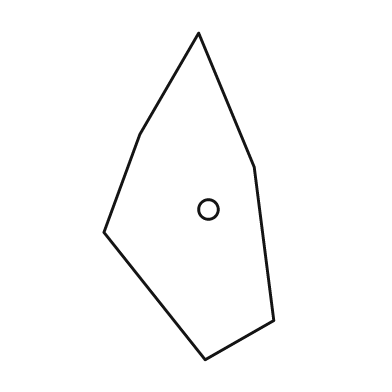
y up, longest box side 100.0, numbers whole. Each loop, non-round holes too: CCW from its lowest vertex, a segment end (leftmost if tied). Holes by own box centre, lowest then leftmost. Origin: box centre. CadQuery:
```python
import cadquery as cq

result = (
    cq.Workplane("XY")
    .moveTo(5.0, -50.0)
    .lineTo(26.0, -38.0)
    .lineTo(20.0, 9.0)
    .lineTo(3.0, 50.0)
    .lineTo(-15.0, 19.0)
    .lineTo(-26.0, -11.0)
    .close()
    .moveTo(6.0, -4.0)
    .circle(3.0)
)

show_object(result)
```